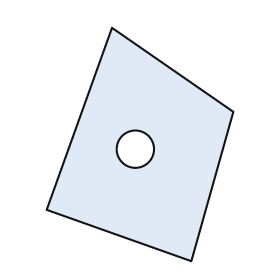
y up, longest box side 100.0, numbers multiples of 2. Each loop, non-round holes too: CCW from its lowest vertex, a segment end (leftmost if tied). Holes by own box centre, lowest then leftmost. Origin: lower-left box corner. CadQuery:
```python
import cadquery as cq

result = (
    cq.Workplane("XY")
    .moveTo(62.0, 0.0)
    .lineTo(80.0, 64.0)
    .lineTo(28.0, 100.0)
    .lineTo(0.0, 22.0)
    .close()
    .moveTo(38.0, 48.0)
    .circle(8.0)
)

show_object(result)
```